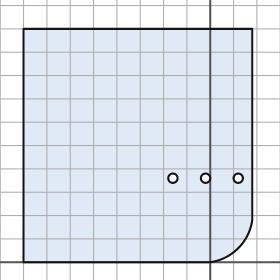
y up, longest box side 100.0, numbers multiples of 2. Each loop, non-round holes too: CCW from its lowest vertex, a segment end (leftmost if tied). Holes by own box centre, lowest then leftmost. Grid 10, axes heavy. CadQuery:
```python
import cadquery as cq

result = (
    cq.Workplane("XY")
    .moveTo(-80.0, 0.0)
    .lineTo(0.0, 0.0)
    .threePointArc((12.0, 6.0), (18.0, 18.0))
    .lineTo(18.0, 100.0)
    .lineTo(-80.0, 100.0)
    .close()
    .moveTo(-16.0, 36.0)
    .circle(2.0)
    .moveTo(-2.0, 36.0)
    .circle(2.0)
    .moveTo(12.0, 36.0)
    .circle(2.0)
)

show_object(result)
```